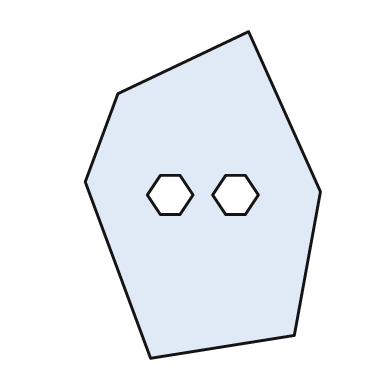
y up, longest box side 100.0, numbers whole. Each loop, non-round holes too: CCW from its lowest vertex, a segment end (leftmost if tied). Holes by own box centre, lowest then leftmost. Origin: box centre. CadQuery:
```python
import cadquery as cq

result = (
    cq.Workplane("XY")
    .moveTo(-16.0, -50.0)
    .lineTo(28.0, -43.0)
    .lineTo(36.0, 1.0)
    .lineTo(14.0, 50.0)
    .lineTo(-26.0, 31.0)
    .lineTo(-36.0, 4.0)
    .close()
    .moveTo(-13.0, -6.0)
    .lineTo(-7.0, -6.0)
    .lineTo(-3.0, 0.0)
    .lineTo(-7.0, 6.0)
    .lineTo(-13.0, 6.0)
    .lineTo(-17.0, 0.0)
    .close()
    .moveTo(7.0, -6.0)
    .lineTo(13.0, -6.0)
    .lineTo(17.0, 0.0)
    .lineTo(13.0, 6.0)
    .lineTo(7.0, 6.0)
    .lineTo(3.0, 0.0)
    .close()
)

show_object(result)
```